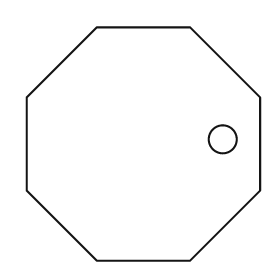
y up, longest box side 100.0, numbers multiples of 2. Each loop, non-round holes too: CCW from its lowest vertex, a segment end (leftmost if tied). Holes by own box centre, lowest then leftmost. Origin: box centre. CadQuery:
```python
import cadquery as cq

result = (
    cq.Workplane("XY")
    .moveTo(-20.0, -50.0)
    .lineTo(20.0, -50.0)
    .lineTo(50.0, -20.0)
    .lineTo(50.0, 20.0)
    .lineTo(20.0, 50.0)
    .lineTo(-20.0, 50.0)
    .lineTo(-50.0, 20.0)
    .lineTo(-50.0, -20.0)
    .close()
    .moveTo(34.0, 2.0)
    .circle(6.0)
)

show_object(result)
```